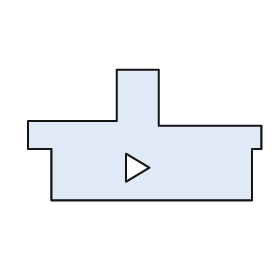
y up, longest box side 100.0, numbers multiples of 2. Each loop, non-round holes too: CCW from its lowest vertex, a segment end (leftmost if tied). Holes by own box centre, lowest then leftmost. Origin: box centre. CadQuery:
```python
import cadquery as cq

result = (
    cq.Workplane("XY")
    .moveTo(-40.0, -28.0)
    .lineTo(46.0, -28.0)
    .lineTo(46.0, -6.0)
    .lineTo(50.0, -6.0)
    .lineTo(50.0, 4.0)
    .lineTo(6.0, 4.0)
    .lineTo(6.0, 28.0)
    .lineTo(-12.0, 28.0)
    .lineTo(-12.0, 6.0)
    .lineTo(-50.0, 6.0)
    .lineTo(-50.0, -6.0)
    .lineTo(-40.0, -6.0)
    .close()
    .moveTo(-8.0, -20.0)
    .lineTo(2.0, -14.0)
    .lineTo(-8.0, -8.0)
    .close()
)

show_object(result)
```